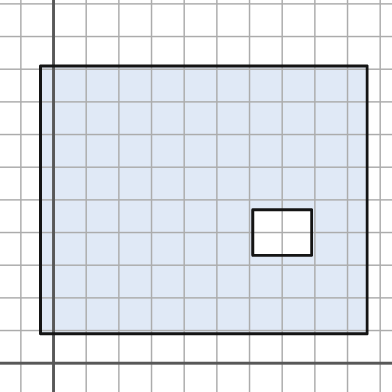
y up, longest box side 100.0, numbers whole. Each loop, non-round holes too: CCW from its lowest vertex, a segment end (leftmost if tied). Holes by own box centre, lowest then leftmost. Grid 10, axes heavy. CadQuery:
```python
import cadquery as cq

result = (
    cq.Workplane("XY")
    .moveTo(-4.0, 9.0)
    .lineTo(96.0, 9.0)
    .lineTo(96.0, 91.0)
    .lineTo(-4.0, 91.0)
    .close()
    .moveTo(61.0, 33.0)
    .lineTo(79.0, 33.0)
    .lineTo(79.0, 47.0)
    .lineTo(61.0, 47.0)
    .close()
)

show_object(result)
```